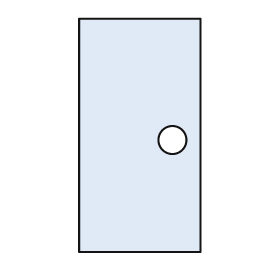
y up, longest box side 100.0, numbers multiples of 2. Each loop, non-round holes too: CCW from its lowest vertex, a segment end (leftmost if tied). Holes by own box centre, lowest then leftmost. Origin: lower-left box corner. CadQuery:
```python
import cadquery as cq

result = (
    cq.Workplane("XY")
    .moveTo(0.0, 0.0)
    .lineTo(52.0, 0.0)
    .lineTo(52.0, 100.0)
    .lineTo(0.0, 100.0)
    .close()
    .moveTo(40.0, 48.0)
    .circle(6.0)
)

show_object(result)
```